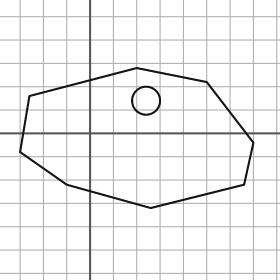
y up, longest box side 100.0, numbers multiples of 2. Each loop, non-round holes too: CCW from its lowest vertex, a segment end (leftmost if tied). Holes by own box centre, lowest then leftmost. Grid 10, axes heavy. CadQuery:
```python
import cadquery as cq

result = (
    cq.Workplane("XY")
    .moveTo(26.0, -32.0)
    .lineTo(66.0, -22.0)
    .lineTo(70.0, -4.0)
    .lineTo(50.0, 22.0)
    .lineTo(20.0, 28.0)
    .lineTo(-26.0, 16.0)
    .lineTo(-30.0, -8.0)
    .lineTo(-10.0, -22.0)
    .close()
    .moveTo(24.0, 14.0)
    .circle(6.0)
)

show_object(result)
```